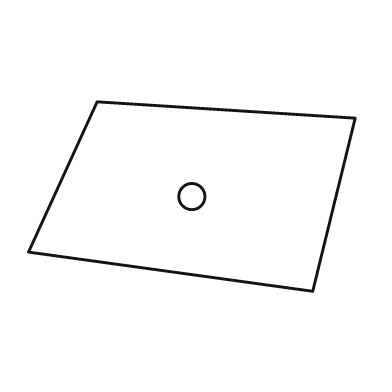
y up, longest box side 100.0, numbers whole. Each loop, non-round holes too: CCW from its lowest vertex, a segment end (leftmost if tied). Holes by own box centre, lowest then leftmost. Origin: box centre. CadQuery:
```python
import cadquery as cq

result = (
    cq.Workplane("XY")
    .moveTo(37.0, -29.0)
    .lineTo(50.0, 24.0)
    .lineTo(-29.0, 29.0)
    .lineTo(-50.0, -17.0)
    .close()
    .moveTo(0.0, 0.0)
    .circle(4.0)
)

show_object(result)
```